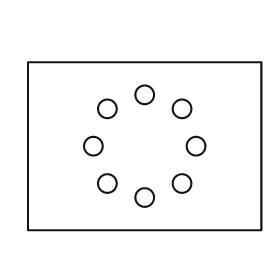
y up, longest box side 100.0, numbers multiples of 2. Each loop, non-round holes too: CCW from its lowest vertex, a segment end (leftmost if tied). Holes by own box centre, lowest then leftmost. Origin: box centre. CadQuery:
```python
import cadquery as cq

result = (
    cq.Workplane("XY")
    .moveTo(-50.0, -36.0)
    .lineTo(50.0, -36.0)
    .lineTo(50.0, 36.0)
    .lineTo(-50.0, 36.0)
    .close()
    .moveTo(0.0, -22.0)
    .circle(4.0)
    .moveTo(-16.0, -16.0)
    .circle(4.0)
    .moveTo(16.0, -16.0)
    .circle(4.0)
    .moveTo(-22.0, 0.0)
    .circle(4.0)
    .moveTo(22.0, 0.0)
    .circle(4.0)
    .moveTo(-16.0, 16.0)
    .circle(4.0)
    .moveTo(16.0, 16.0)
    .circle(4.0)
    .moveTo(0.0, 22.0)
    .circle(4.0)
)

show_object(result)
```